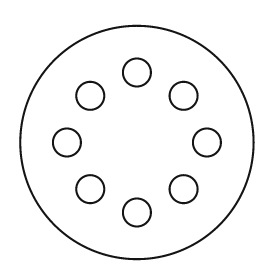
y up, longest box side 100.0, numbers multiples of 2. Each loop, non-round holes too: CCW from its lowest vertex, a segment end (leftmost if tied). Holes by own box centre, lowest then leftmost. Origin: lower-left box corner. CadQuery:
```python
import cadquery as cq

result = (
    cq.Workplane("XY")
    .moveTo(50.0, 50.0)
    .circle(50.0)
    .moveTo(50.0, 20.0)
    .circle(6.0)
    .moveTo(30.0, 30.0)
    .circle(6.0)
    .moveTo(70.0, 30.0)
    .circle(6.0)
    .moveTo(20.0, 50.0)
    .circle(6.0)
    .moveTo(80.0, 50.0)
    .circle(6.0)
    .moveTo(30.0, 70.0)
    .circle(6.0)
    .moveTo(70.0, 70.0)
    .circle(6.0)
    .moveTo(50.0, 80.0)
    .circle(6.0)
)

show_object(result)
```